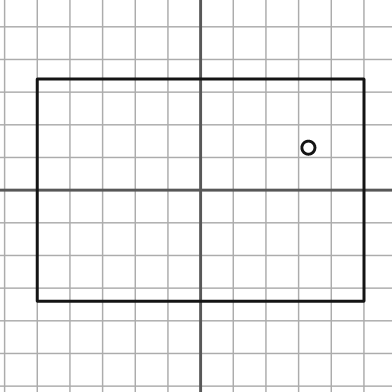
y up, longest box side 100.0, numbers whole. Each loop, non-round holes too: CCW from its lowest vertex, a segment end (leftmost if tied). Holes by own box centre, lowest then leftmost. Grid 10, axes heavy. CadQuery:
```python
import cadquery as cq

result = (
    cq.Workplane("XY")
    .moveTo(-50.0, -34.0)
    .lineTo(50.0, -34.0)
    .lineTo(50.0, 34.0)
    .lineTo(-50.0, 34.0)
    .close()
    .moveTo(33.0, 13.0)
    .circle(2.0)
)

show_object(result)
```